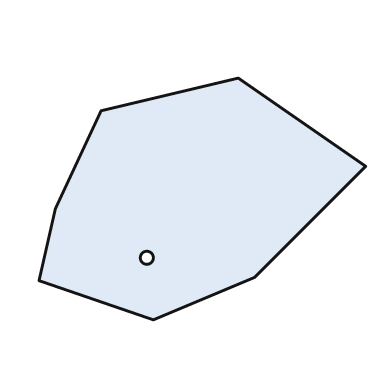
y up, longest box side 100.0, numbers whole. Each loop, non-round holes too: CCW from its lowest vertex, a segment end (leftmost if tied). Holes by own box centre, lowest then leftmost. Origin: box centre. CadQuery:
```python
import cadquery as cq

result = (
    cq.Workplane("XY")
    .moveTo(-15.0, -37.0)
    .lineTo(16.0, -24.0)
    .lineTo(50.0, 10.0)
    .lineTo(11.0, 37.0)
    .lineTo(-31.0, 27.0)
    .lineTo(-45.0, -3.0)
    .lineTo(-50.0, -25.0)
    .close()
    .moveTo(-17.0, -18.0)
    .circle(2.0)
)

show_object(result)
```